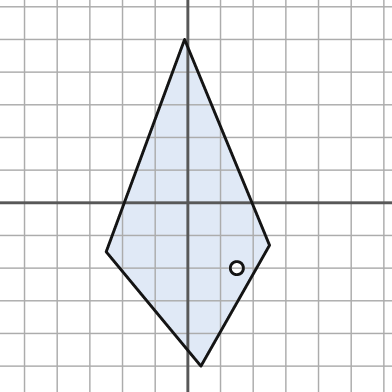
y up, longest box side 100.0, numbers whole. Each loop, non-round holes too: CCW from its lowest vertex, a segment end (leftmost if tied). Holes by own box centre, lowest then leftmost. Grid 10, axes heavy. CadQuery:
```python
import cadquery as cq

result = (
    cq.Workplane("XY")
    .moveTo(4.0, -50.0)
    .lineTo(25.0, -13.0)
    .lineTo(-1.0, 50.0)
    .lineTo(-25.0, -15.0)
    .close()
    .moveTo(15.0, -20.0)
    .circle(2.0)
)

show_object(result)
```